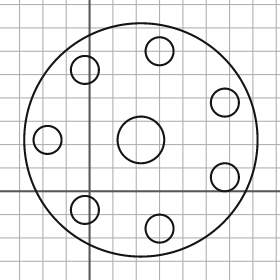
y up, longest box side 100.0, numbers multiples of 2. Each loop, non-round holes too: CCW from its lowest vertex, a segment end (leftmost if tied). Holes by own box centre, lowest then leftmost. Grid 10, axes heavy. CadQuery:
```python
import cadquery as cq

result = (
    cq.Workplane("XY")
    .moveTo(22.0, 22.0)
    .circle(50.0)
    .moveTo(30.0, -16.0)
    .circle(6.0)
    .moveTo(-2.0, -8.0)
    .circle(6.0)
    .moveTo(58.0, 6.0)
    .circle(6.0)
    .moveTo(-18.0, 22.0)
    .circle(6.0)
    .moveTo(22.0, 22.0)
    .circle(10.0)
    .moveTo(58.0, 38.0)
    .circle(6.0)
    .moveTo(-2.0, 52.0)
    .circle(6.0)
    .moveTo(30.0, 60.0)
    .circle(6.0)
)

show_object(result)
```